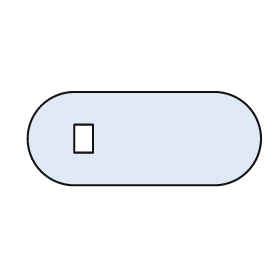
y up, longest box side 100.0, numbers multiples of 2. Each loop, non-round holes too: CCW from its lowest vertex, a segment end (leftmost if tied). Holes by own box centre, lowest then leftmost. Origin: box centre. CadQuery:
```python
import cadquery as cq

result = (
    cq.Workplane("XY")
    .moveTo(-30.0, -20.0)
    .lineTo(30.0, -20.0)
    .threePointArc((50.0, 0.0), (30.0, 20.0))
    .lineTo(-30.0, 20.0)
    .threePointArc((-50.0, 0.0), (-30.0, -20.0))
    .close()
    .moveTo(-30.0, -6.0)
    .lineTo(-22.0, -6.0)
    .lineTo(-22.0, 6.0)
    .lineTo(-30.0, 6.0)
    .close()
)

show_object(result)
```